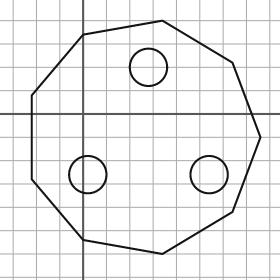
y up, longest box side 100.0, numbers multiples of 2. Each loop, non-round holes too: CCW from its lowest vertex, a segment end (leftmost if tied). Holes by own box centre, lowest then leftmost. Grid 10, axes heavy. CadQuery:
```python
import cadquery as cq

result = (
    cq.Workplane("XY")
    .moveTo(34.0, -60.0)
    .lineTo(64.0, -42.0)
    .lineTo(76.0, -10.0)
    .lineTo(64.0, 22.0)
    .lineTo(34.0, 40.0)
    .lineTo(0.0, 34.0)
    .lineTo(-22.0, 8.0)
    .lineTo(-22.0, -28.0)
    .lineTo(0.0, -54.0)
    .close()
    .moveTo(2.0, -26.0)
    .circle(8.0)
    .moveTo(54.0, -26.0)
    .circle(8.0)
    .moveTo(28.0, 20.0)
    .circle(8.0)
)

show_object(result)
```